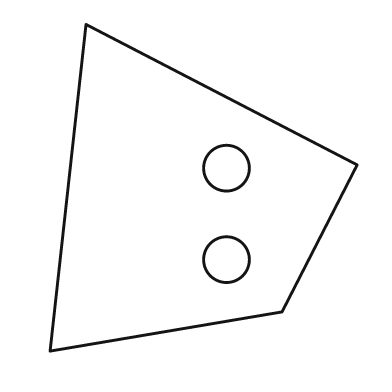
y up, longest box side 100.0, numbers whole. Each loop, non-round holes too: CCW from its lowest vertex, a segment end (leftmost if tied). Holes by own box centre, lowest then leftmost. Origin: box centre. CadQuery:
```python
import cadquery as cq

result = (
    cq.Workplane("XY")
    .moveTo(-47.0, -50.0)
    .lineTo(24.0, -38.0)
    .lineTo(47.0, 7.0)
    .lineTo(-36.0, 50.0)
    .close()
    .moveTo(7.0, -22.0)
    .circle(7.0)
    .moveTo(7.0, 6.0)
    .circle(7.0)
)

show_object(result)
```